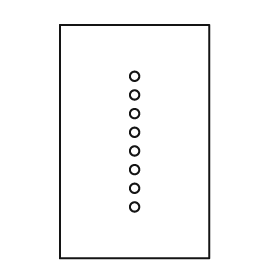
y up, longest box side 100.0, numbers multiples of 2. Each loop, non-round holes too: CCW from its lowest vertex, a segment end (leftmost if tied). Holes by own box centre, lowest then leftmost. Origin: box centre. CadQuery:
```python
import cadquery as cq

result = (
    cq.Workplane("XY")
    .moveTo(-32.0, -50.0)
    .lineTo(32.0, -50.0)
    .lineTo(32.0, 50.0)
    .lineTo(-32.0, 50.0)
    .close()
    .moveTo(0.0, -28.0)
    .circle(2.0)
    .moveTo(0.0, -20.0)
    .circle(2.0)
    .moveTo(0.0, -12.0)
    .circle(2.0)
    .moveTo(0.0, -4.0)
    .circle(2.0)
    .moveTo(0.0, 4.0)
    .circle(2.0)
    .moveTo(0.0, 12.0)
    .circle(2.0)
    .moveTo(0.0, 20.0)
    .circle(2.0)
    .moveTo(0.0, 28.0)
    .circle(2.0)
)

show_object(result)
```